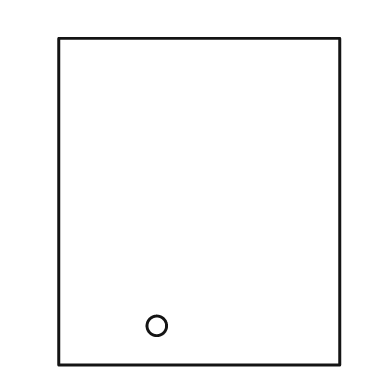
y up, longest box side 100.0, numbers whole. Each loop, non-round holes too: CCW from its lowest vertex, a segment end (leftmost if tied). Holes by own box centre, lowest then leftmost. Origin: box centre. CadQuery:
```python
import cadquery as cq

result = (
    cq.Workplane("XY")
    .moveTo(-43.0, -50.0)
    .lineTo(43.0, -50.0)
    .lineTo(43.0, 50.0)
    .lineTo(-43.0, 50.0)
    .close()
    .moveTo(-13.0, -38.0)
    .circle(3.0)
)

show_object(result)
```